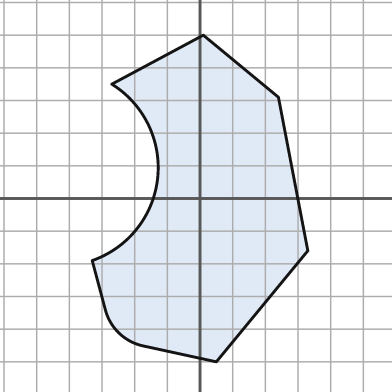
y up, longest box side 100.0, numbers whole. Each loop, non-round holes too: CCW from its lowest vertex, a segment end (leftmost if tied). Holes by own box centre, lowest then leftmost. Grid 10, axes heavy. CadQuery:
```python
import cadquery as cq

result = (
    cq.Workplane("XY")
    .moveTo(5.0, -50.0)
    .lineTo(33.0, -16.0)
    .lineTo(24.0, 31.0)
    .lineTo(1.0, 50.0)
    .lineTo(-27.0, 35.0)
    .threePointArc((-13.0, 6.0), (-33.0, -19.0))
    .lineTo(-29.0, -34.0)
    .threePointArc((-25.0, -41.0), (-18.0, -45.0))
    .close()
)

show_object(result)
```